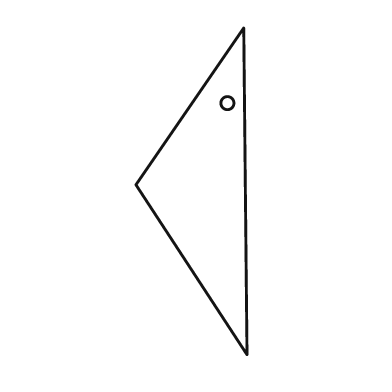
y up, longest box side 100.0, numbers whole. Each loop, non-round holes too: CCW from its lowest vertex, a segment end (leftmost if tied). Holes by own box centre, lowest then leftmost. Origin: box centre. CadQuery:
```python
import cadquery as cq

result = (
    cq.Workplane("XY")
    .moveTo(17.0, -50.0)
    .lineTo(16.0, 50.0)
    .lineTo(-17.0, 2.0)
    .close()
    .moveTo(11.0, 27.0)
    .circle(2.0)
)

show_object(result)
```